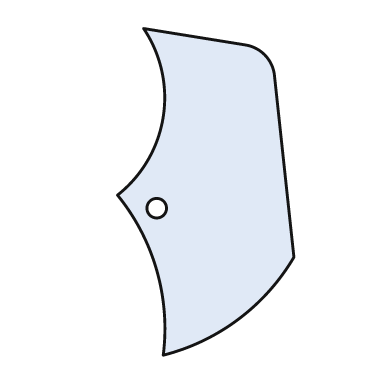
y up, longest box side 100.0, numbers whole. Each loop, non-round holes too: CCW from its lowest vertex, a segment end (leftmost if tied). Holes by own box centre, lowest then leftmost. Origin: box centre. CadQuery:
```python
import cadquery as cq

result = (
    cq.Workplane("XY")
    .moveTo(-13.0, -50.0)
    .threePointArc((10.0, -39.0), (27.0, -20.0))
    .lineTo(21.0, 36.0)
    .threePointArc((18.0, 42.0), (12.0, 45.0))
    .lineTo(-19.0, 50.0)
    .threePointArc((-13.0, 23.0), (-27.0, -1.0))
    .threePointArc((-15.0, -24.0), (-13.0, -50.0))
    .close()
    .moveTo(-15.0, -5.0)
    .circle(3.0)
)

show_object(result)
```